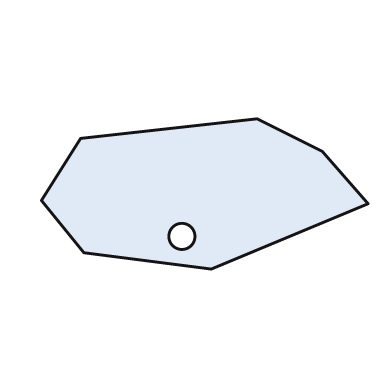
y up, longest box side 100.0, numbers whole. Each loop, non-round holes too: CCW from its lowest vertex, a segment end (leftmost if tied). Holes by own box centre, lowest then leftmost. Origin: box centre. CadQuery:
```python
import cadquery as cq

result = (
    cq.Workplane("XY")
    .moveTo(2.0, -23.0)
    .lineTo(50.0, -3.0)
    .lineTo(36.0, 13.0)
    .lineTo(16.0, 23.0)
    .lineTo(-38.0, 17.0)
    .lineTo(-50.0, -2.0)
    .lineTo(-37.0, -18.0)
    .close()
    .moveTo(-7.0, -13.0)
    .circle(4.0)
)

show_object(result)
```